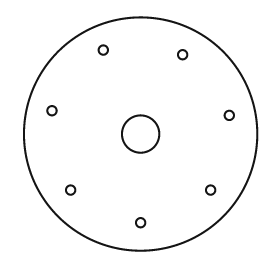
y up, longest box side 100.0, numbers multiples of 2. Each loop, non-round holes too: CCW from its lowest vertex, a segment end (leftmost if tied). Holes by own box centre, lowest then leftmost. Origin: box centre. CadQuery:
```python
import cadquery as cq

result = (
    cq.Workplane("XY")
    .moveTo(0.0, 0.0)
    .circle(50.0)
    .moveTo(0.0, -38.0)
    .circle(2.0)
    .moveTo(-30.0, -24.0)
    .circle(2.0)
    .moveTo(30.0, -24.0)
    .circle(2.0)
    .moveTo(0.0, 0.0)
    .circle(8.0)
    .moveTo(38.0, 8.0)
    .circle(2.0)
    .moveTo(-38.0, 10.0)
    .circle(2.0)
    .moveTo(18.0, 34.0)
    .circle(2.0)
    .moveTo(-16.0, 36.0)
    .circle(2.0)
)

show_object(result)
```